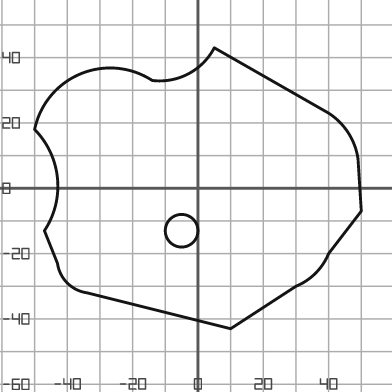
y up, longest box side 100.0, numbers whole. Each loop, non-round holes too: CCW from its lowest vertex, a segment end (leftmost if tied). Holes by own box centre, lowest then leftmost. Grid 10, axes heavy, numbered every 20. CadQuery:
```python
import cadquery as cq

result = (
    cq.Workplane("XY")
    .moveTo(10.0, -43.0)
    .lineTo(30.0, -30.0)
    .threePointArc((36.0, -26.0), (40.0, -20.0))
    .lineTo(50.0, -7.0)
    .lineTo(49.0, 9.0)
    .threePointArc((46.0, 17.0), (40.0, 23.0))
    .lineTo(5.0, 43.0)
    .threePointArc((-3.0, 35.0), (-14.0, 33.0))
    .threePointArc((-36.0, 35.0), (-50.0, 18.0))
    .threePointArc((-43.0, 3.0), (-47.0, -13.0))
    .lineTo(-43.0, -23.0)
    .threePointArc((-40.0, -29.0), (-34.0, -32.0))
    .close()
    .moveTo(-5.0, -13.0)
    .circle(5.0)
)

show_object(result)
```